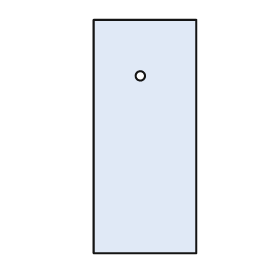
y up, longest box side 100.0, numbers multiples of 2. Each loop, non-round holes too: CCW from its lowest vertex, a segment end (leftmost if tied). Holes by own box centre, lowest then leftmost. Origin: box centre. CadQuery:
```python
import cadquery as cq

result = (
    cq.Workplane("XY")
    .moveTo(-22.0, -50.0)
    .lineTo(22.0, -50.0)
    .lineTo(22.0, 50.0)
    .lineTo(-22.0, 50.0)
    .close()
    .moveTo(-2.0, 26.0)
    .circle(2.0)
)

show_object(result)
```